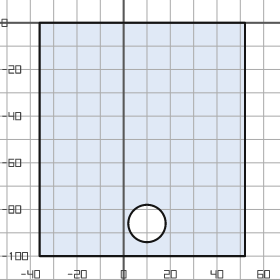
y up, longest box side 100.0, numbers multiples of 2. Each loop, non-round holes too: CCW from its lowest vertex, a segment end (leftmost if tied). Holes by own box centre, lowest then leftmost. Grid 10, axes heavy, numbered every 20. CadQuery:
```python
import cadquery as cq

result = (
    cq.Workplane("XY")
    .moveTo(-36.0, -100.0)
    .lineTo(52.0, -100.0)
    .lineTo(52.0, 0.0)
    .lineTo(-36.0, 0.0)
    .close()
    .moveTo(10.0, -86.0)
    .circle(8.0)
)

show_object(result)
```